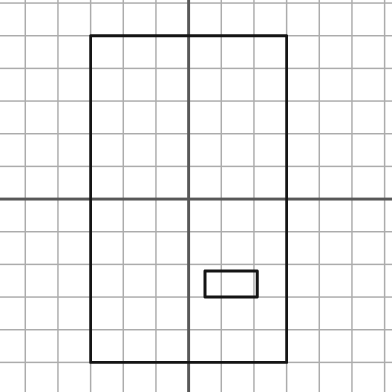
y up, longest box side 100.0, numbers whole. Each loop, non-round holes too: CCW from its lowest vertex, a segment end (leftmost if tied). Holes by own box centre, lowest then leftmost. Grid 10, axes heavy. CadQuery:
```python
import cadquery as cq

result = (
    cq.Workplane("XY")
    .moveTo(-30.0, -50.0)
    .lineTo(30.0, -50.0)
    .lineTo(30.0, 50.0)
    .lineTo(-30.0, 50.0)
    .close()
    .moveTo(5.0, -30.0)
    .lineTo(21.0, -30.0)
    .lineTo(21.0, -22.0)
    .lineTo(5.0, -22.0)
    .close()
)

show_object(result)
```